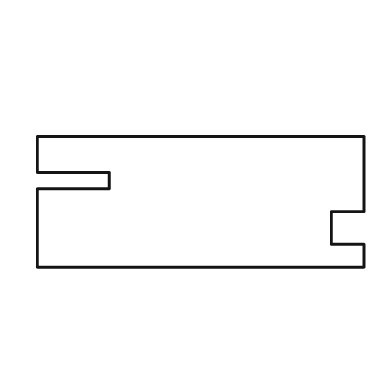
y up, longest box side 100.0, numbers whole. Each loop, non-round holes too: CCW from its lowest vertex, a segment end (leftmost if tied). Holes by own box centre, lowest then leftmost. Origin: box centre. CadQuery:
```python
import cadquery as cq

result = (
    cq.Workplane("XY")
    .moveTo(-50.0, -20.0)
    .lineTo(50.0, -20.0)
    .lineTo(50.0, -13.0)
    .lineTo(40.0, -13.0)
    .lineTo(40.0, -3.0)
    .lineTo(50.0, -3.0)
    .lineTo(50.0, 20.0)
    .lineTo(-50.0, 20.0)
    .lineTo(-50.0, 9.0)
    .lineTo(-28.0, 9.0)
    .lineTo(-28.0, 4.0)
    .lineTo(-50.0, 4.0)
    .close()
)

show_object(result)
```